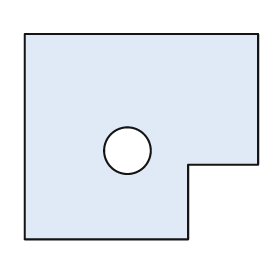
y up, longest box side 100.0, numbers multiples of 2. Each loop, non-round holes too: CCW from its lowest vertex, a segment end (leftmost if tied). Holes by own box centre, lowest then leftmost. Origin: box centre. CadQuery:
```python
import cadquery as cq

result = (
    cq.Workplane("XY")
    .moveTo(-50.0, -44.0)
    .lineTo(20.0, -44.0)
    .lineTo(20.0, -12.0)
    .lineTo(50.0, -12.0)
    .lineTo(50.0, 44.0)
    .lineTo(-50.0, 44.0)
    .close()
    .moveTo(-6.0, -6.0)
    .circle(10.0)
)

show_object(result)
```